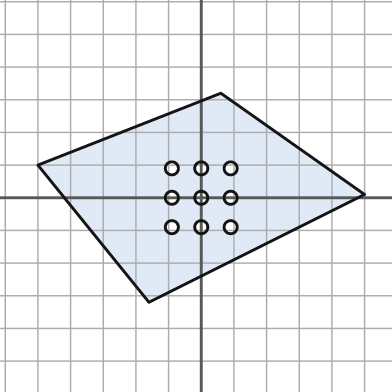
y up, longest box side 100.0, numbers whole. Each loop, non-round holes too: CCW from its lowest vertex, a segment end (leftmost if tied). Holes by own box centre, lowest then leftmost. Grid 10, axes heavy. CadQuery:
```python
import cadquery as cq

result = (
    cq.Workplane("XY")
    .moveTo(-16.0, -32.0)
    .lineTo(50.0, 1.0)
    .lineTo(6.0, 32.0)
    .lineTo(-50.0, 10.0)
    .close()
    .moveTo(-9.0, -9.0)
    .circle(2.0)
    .moveTo(0.0, -9.0)
    .circle(2.0)
    .moveTo(9.0, -9.0)
    .circle(2.0)
    .moveTo(-9.0, 0.0)
    .circle(2.0)
    .moveTo(0.0, 0.0)
    .circle(2.0)
    .moveTo(9.0, 0.0)
    .circle(2.0)
    .moveTo(-9.0, 9.0)
    .circle(2.0)
    .moveTo(0.0, 9.0)
    .circle(2.0)
    .moveTo(9.0, 9.0)
    .circle(2.0)
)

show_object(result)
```